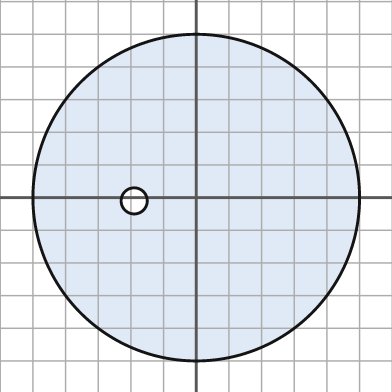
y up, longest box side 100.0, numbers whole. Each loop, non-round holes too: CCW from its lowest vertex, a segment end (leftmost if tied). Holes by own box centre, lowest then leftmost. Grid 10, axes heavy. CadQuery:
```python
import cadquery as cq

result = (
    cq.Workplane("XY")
    .moveTo(0.0, 0.0)
    .circle(50.0)
    .moveTo(-19.0, -1.0)
    .circle(4.0)
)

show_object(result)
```